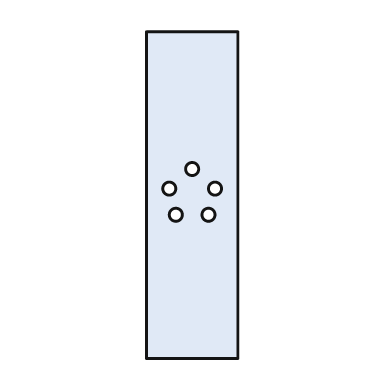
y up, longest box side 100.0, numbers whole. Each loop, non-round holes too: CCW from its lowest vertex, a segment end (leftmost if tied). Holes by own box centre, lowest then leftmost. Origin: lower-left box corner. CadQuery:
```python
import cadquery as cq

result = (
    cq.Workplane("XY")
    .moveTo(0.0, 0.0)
    .lineTo(28.0, 0.0)
    .lineTo(28.0, 100.0)
    .lineTo(0.0, 100.0)
    .close()
    .moveTo(9.0, 44.0)
    .circle(2.0)
    .moveTo(19.0, 44.0)
    .circle(2.0)
    .moveTo(7.0, 52.0)
    .circle(2.0)
    .moveTo(21.0, 52.0)
    .circle(2.0)
    .moveTo(14.0, 58.0)
    .circle(2.0)
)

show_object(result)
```